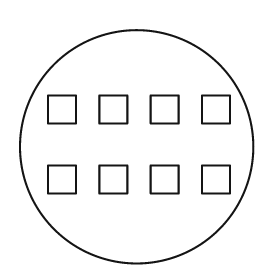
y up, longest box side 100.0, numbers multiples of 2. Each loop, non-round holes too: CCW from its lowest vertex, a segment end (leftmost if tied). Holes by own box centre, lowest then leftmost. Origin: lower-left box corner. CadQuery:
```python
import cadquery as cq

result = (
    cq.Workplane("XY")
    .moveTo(50.0, 50.0)
    .circle(50.0)
    .moveTo(12.0, 30.0)
    .lineTo(24.0, 30.0)
    .lineTo(24.0, 42.0)
    .lineTo(12.0, 42.0)
    .close()
    .moveTo(34.0, 30.0)
    .lineTo(46.0, 30.0)
    .lineTo(46.0, 42.0)
    .lineTo(34.0, 42.0)
    .close()
    .moveTo(56.0, 30.0)
    .lineTo(68.0, 30.0)
    .lineTo(68.0, 42.0)
    .lineTo(56.0, 42.0)
    .close()
    .moveTo(78.0, 30.0)
    .lineTo(90.0, 30.0)
    .lineTo(90.0, 42.0)
    .lineTo(78.0, 42.0)
    .close()
    .moveTo(12.0, 60.0)
    .lineTo(24.0, 60.0)
    .lineTo(24.0, 72.0)
    .lineTo(12.0, 72.0)
    .close()
    .moveTo(34.0, 60.0)
    .lineTo(46.0, 60.0)
    .lineTo(46.0, 72.0)
    .lineTo(34.0, 72.0)
    .close()
    .moveTo(56.0, 60.0)
    .lineTo(68.0, 60.0)
    .lineTo(68.0, 72.0)
    .lineTo(56.0, 72.0)
    .close()
    .moveTo(78.0, 60.0)
    .lineTo(90.0, 60.0)
    .lineTo(90.0, 72.0)
    .lineTo(78.0, 72.0)
    .close()
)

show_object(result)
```